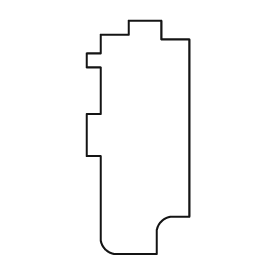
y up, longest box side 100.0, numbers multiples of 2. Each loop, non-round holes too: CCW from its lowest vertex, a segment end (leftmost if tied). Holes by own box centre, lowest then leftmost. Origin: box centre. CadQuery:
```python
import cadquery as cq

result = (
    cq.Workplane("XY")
    .moveTo(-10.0, -50.0)
    .lineTo(8.0, -50.0)
    .lineTo(8.0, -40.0)
    .threePointArc((10.0, -36.0), (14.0, -34.0))
    .lineTo(22.0, -34.0)
    .lineTo(22.0, 42.0)
    .lineTo(10.0, 42.0)
    .lineTo(10.0, 50.0)
    .lineTo(-4.0, 50.0)
    .lineTo(-4.0, 44.0)
    .lineTo(-16.0, 44.0)
    .lineTo(-16.0, 36.0)
    .lineTo(-22.0, 36.0)
    .lineTo(-22.0, 30.0)
    .lineTo(-16.0, 30.0)
    .lineTo(-16.0, 10.0)
    .lineTo(-22.0, 10.0)
    .lineTo(-22.0, -8.0)
    .lineTo(-16.0, -8.0)
    .lineTo(-16.0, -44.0)
    .threePointArc((-14.0, -48.0), (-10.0, -50.0))
    .close()
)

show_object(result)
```